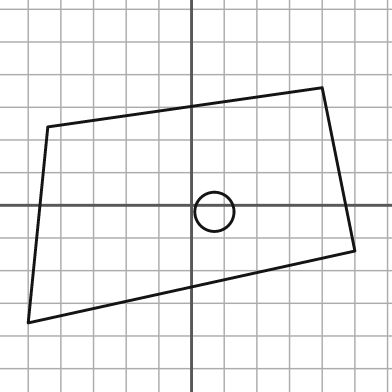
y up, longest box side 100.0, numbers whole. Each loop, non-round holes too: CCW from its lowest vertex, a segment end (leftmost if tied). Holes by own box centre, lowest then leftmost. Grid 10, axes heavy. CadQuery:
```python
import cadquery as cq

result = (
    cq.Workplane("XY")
    .moveTo(-50.0, -36.0)
    .lineTo(50.0, -14.0)
    .lineTo(40.0, 36.0)
    .lineTo(-44.0, 24.0)
    .close()
    .moveTo(7.0, -2.0)
    .circle(6.0)
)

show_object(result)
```